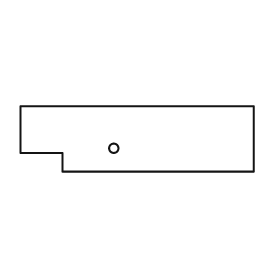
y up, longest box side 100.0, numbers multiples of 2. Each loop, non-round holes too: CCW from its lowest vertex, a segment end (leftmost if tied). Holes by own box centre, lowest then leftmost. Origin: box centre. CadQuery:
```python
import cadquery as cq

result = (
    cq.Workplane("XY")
    .moveTo(-32.0, -14.0)
    .lineTo(50.0, -14.0)
    .lineTo(50.0, 14.0)
    .lineTo(-50.0, 14.0)
    .lineTo(-50.0, -6.0)
    .lineTo(-32.0, -6.0)
    .close()
    .moveTo(-10.0, -4.0)
    .circle(2.0)
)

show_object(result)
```